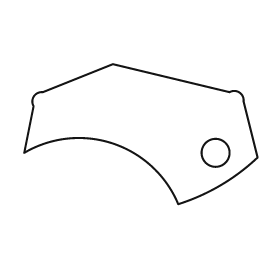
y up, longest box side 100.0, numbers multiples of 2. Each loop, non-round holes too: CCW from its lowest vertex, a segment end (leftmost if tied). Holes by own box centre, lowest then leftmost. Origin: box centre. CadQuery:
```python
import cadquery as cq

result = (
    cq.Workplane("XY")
    .moveTo(16.0, -30.0)
    .threePointArc((34.0, -22.0), (50.0, -10.0))
    .lineTo(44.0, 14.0)
    .threePointArc((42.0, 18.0), (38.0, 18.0))
    .lineTo(-12.0, 30.0)
    .lineTo(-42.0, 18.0)
    .threePointArc((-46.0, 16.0), (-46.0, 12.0))
    .lineTo(-50.0, -8.0)
    .threePointArc((-12.0, -4.0), (16.0, -30.0))
    .close()
    .moveTo(32.0, -8.0)
    .circle(6.0)
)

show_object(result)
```